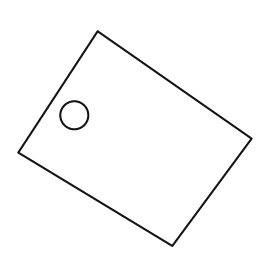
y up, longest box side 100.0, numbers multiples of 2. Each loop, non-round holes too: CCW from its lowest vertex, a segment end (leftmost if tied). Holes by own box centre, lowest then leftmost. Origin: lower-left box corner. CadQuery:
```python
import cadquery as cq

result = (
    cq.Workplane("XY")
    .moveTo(66.0, 0.0)
    .lineTo(100.0, 46.0)
    .lineTo(34.0, 92.0)
    .lineTo(0.0, 40.0)
    .close()
    .moveTo(24.0, 56.0)
    .circle(6.0)
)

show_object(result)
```